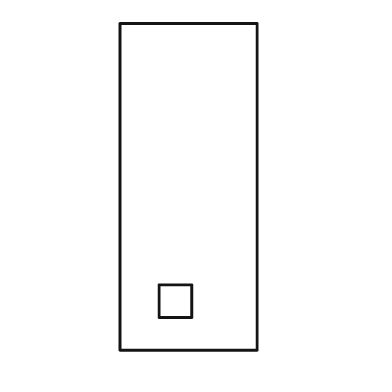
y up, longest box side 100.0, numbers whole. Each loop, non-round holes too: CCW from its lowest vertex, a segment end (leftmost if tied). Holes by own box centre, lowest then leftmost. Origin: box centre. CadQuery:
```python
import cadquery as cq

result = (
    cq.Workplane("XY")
    .moveTo(-21.0, -50.0)
    .lineTo(21.0, -50.0)
    .lineTo(21.0, 50.0)
    .lineTo(-21.0, 50.0)
    .close()
    .moveTo(-9.0, -40.0)
    .lineTo(1.0, -40.0)
    .lineTo(1.0, -30.0)
    .lineTo(-9.0, -30.0)
    .close()
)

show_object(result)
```